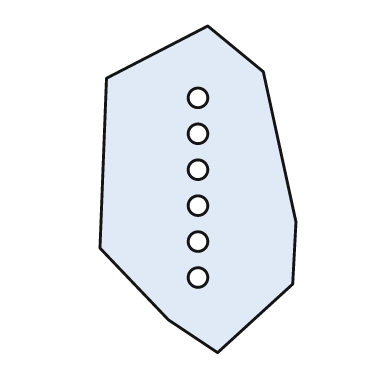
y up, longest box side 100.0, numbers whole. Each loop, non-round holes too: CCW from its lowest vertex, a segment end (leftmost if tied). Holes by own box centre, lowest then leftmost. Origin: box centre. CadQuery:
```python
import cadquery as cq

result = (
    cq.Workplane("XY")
    .moveTo(6.0, -50.0)
    .lineTo(29.0, -29.0)
    .lineTo(30.0, -10.0)
    .lineTo(20.0, 36.0)
    .lineTo(3.0, 50.0)
    .lineTo(-28.0, 34.0)
    .lineTo(-30.0, -18.0)
    .lineTo(-9.0, -40.0)
    .close()
    .moveTo(0.0, -27.0)
    .circle(3.0)
    .moveTo(0.0, -16.0)
    .circle(3.0)
    .moveTo(0.0, -5.0)
    .circle(3.0)
    .moveTo(0.0, 6.0)
    .circle(3.0)
    .moveTo(0.0, 17.0)
    .circle(3.0)
    .moveTo(0.0, 28.0)
    .circle(3.0)
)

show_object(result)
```